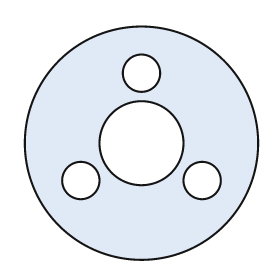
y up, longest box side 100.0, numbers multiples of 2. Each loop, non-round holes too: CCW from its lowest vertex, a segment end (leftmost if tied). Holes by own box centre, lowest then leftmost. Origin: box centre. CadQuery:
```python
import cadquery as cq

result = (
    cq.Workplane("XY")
    .moveTo(0.0, 0.0)
    .circle(50.0)
    .moveTo(-26.0, -16.0)
    .circle(8.0)
    .moveTo(26.0, -16.0)
    .circle(8.0)
    .moveTo(0.0, 0.0)
    .circle(18.0)
    .moveTo(0.0, 30.0)
    .circle(8.0)
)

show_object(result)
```